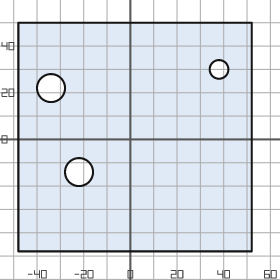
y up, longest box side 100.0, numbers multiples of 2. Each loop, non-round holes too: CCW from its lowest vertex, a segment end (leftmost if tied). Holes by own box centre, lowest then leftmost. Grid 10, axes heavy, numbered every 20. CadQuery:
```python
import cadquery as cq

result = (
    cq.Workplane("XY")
    .moveTo(-48.0, -48.0)
    .lineTo(52.0, -48.0)
    .lineTo(52.0, 50.0)
    .lineTo(-48.0, 50.0)
    .close()
    .moveTo(-22.0, -14.0)
    .circle(6.0)
    .moveTo(-34.0, 22.0)
    .circle(6.0)
    .moveTo(38.0, 30.0)
    .circle(4.0)
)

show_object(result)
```